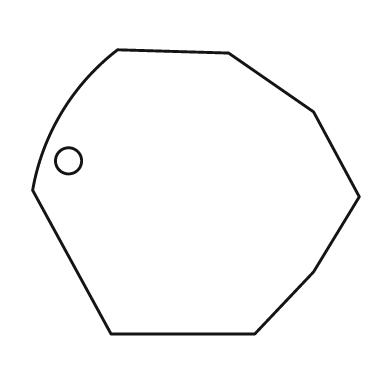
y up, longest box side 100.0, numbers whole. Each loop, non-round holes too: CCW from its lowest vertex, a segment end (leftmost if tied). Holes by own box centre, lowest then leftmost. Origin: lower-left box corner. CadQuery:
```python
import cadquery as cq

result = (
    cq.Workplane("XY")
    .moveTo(24.0, 0.0)
    .lineTo(68.0, 0.0)
    .lineTo(86.0, 19.0)
    .lineTo(100.0, 42.0)
    .lineTo(86.0, 68.0)
    .lineTo(60.0, 86.0)
    .lineTo(26.0, 87.0)
    .threePointArc((9.0, 68.0), (0.0, 44.0))
    .close()
    .moveTo(11.0, 53.0)
    .circle(4.0)
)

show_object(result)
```